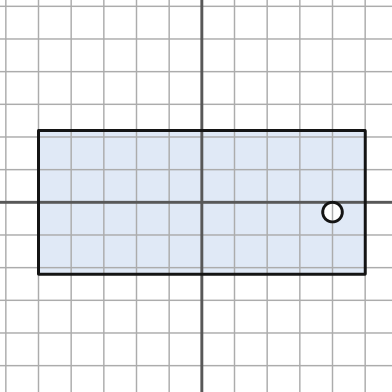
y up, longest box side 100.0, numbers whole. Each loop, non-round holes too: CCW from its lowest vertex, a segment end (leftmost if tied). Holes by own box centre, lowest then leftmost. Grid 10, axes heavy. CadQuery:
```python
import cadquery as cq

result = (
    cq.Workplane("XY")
    .moveTo(-50.0, -22.0)
    .lineTo(50.0, -22.0)
    .lineTo(50.0, 22.0)
    .lineTo(-50.0, 22.0)
    .close()
    .moveTo(40.0, -3.0)
    .circle(3.0)
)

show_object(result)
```